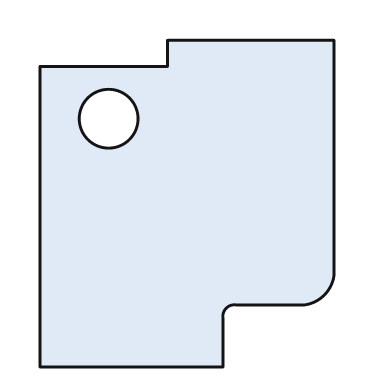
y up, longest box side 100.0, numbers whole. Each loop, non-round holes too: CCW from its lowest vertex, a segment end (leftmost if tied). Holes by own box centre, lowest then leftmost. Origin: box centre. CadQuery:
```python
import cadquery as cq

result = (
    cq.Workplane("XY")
    .moveTo(-45.0, -50.0)
    .lineTo(11.0, -50.0)
    .lineTo(11.0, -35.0)
    .threePointArc((12.0, -32.0), (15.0, -31.0))
    .lineTo(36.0, -31.0)
    .threePointArc((42.0, -28.0), (45.0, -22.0))
    .lineTo(45.0, 50.0)
    .lineTo(-6.0, 50.0)
    .lineTo(-6.0, 42.0)
    .lineTo(-45.0, 42.0)
    .close()
    .moveTo(-24.0, 26.0)
    .circle(9.0)
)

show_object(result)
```